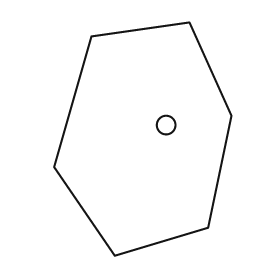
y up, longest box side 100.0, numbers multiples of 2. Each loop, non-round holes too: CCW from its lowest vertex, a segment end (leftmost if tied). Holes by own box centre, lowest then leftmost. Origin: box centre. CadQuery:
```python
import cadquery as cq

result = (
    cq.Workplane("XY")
    .moveTo(-12.0, -50.0)
    .lineTo(28.0, -38.0)
    .lineTo(38.0, 10.0)
    .lineTo(20.0, 50.0)
    .lineTo(-22.0, 44.0)
    .lineTo(-38.0, -12.0)
    .close()
    .moveTo(10.0, 6.0)
    .circle(4.0)
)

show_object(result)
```